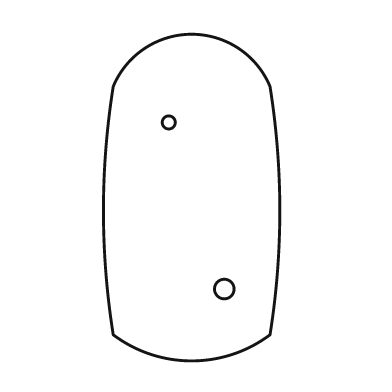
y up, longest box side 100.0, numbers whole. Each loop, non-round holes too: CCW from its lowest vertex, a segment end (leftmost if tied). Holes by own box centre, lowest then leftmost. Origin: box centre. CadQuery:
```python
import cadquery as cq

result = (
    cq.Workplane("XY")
    .moveTo(-24.0, -42.0)
    .threePointArc((0.0, -50.0), (24.0, -42.0))
    .threePointArc((27.0, -4.0), (24.0, 34.0))
    .threePointArc((0.0, 50.0), (-24.0, 34.0))
    .threePointArc((-27.0, -4.0), (-24.0, -42.0))
    .close()
    .moveTo(10.0, -28.0)
    .circle(3.0)
    .moveTo(-7.0, 23.0)
    .circle(2.0)
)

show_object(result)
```